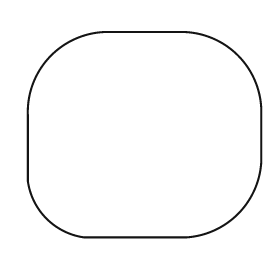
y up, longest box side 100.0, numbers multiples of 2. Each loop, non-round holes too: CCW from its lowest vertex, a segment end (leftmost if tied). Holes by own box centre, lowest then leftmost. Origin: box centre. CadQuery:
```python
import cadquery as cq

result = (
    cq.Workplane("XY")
    .moveTo(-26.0, -44.0)
    .lineTo(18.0, -44.0)
    .threePointArc((40.0, -34.0), (50.0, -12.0))
    .lineTo(50.0, 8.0)
    .threePointArc((40.0, 34.0), (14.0, 44.0))
    .lineTo(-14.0, 44.0)
    .threePointArc((-40.0, 34.0), (-50.0, 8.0))
    .lineTo(-50.0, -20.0)
    .threePointArc((-42.0, -36.0), (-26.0, -44.0))
    .close()
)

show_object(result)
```